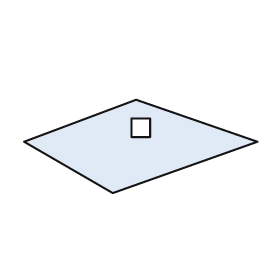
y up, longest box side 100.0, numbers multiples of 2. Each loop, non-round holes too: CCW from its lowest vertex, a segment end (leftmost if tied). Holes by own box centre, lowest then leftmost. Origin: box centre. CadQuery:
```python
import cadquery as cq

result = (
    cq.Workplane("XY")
    .moveTo(-12.0, -20.0)
    .lineTo(50.0, 2.0)
    .lineTo(-2.0, 20.0)
    .lineTo(-50.0, 2.0)
    .close()
    .moveTo(-4.0, 4.0)
    .lineTo(4.0, 4.0)
    .lineTo(4.0, 12.0)
    .lineTo(-4.0, 12.0)
    .close()
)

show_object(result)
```